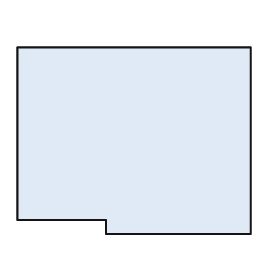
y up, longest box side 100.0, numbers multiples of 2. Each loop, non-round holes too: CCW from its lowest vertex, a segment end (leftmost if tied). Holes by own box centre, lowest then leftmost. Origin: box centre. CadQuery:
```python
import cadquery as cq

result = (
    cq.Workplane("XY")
    .moveTo(-12.0, -40.0)
    .lineTo(50.0, -40.0)
    .lineTo(50.0, 40.0)
    .lineTo(-50.0, 40.0)
    .lineTo(-50.0, -34.0)
    .lineTo(-12.0, -34.0)
    .close()
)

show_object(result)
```